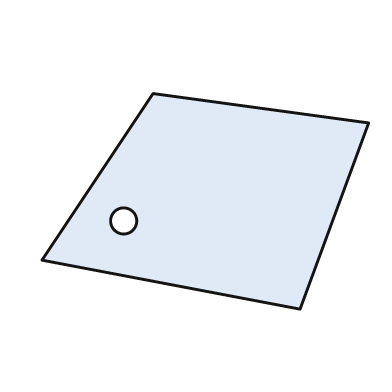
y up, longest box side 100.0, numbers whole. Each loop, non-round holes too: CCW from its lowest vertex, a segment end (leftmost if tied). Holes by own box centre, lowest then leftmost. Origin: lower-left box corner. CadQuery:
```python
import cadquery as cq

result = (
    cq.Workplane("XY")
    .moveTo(79.0, 0.0)
    .lineTo(100.0, 57.0)
    .lineTo(34.0, 66.0)
    .lineTo(0.0, 15.0)
    .close()
    .moveTo(25.0, 27.0)
    .circle(4.0)
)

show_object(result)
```